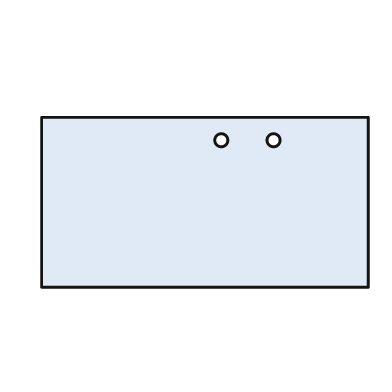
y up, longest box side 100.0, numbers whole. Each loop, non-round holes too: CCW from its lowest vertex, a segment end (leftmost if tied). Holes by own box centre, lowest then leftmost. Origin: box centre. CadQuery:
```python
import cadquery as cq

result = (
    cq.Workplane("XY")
    .moveTo(-50.0, -26.0)
    .lineTo(50.0, -26.0)
    .lineTo(50.0, 26.0)
    .lineTo(-50.0, 26.0)
    .close()
    .moveTo(5.0, 19.0)
    .circle(2.0)
    .moveTo(21.0, 19.0)
    .circle(2.0)
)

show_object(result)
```